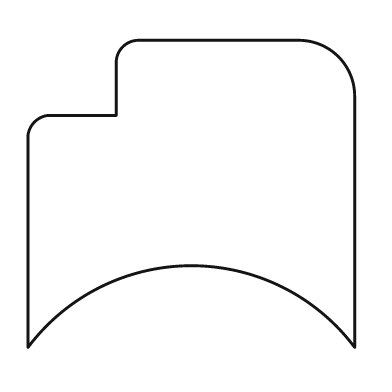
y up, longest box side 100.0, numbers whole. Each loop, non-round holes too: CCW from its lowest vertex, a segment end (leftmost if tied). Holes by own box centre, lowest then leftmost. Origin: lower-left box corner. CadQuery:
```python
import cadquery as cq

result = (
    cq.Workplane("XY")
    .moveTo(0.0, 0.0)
    .threePointArc((50.0, 25.0), (100.0, 0.0))
    .lineTo(100.0, 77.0)
    .threePointArc((95.0, 89.0), (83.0, 94.0))
    .lineTo(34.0, 94.0)
    .threePointArc((29.0, 92.0), (27.0, 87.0))
    .lineTo(27.0, 71.0)
    .lineTo(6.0, 71.0)
    .threePointArc((2.0, 69.0), (0.0, 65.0))
    .close()
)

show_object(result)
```